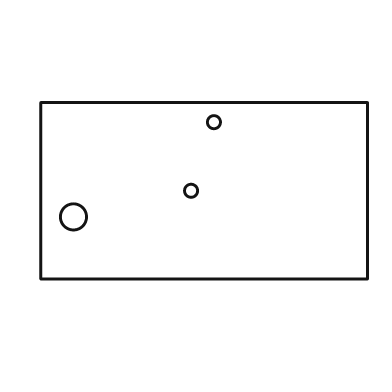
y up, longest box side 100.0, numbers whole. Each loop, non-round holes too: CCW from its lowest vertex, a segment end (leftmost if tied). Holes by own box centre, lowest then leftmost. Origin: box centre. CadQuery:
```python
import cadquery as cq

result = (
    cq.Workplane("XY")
    .moveTo(-50.0, -27.0)
    .lineTo(50.0, -27.0)
    .lineTo(50.0, 27.0)
    .lineTo(-50.0, 27.0)
    .close()
    .moveTo(-40.0, -8.0)
    .circle(4.0)
    .moveTo(-4.0, 0.0)
    .circle(2.0)
    .moveTo(3.0, 21.0)
    .circle(2.0)
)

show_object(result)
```